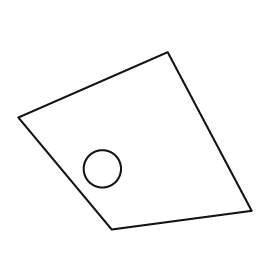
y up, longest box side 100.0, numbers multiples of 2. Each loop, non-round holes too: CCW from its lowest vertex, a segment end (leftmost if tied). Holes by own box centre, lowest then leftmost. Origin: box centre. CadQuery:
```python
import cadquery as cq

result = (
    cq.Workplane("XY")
    .moveTo(-10.0, -38.0)
    .lineTo(50.0, -30.0)
    .lineTo(14.0, 38.0)
    .lineTo(-50.0, 10.0)
    .close()
    .moveTo(-14.0, -12.0)
    .circle(8.0)
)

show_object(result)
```